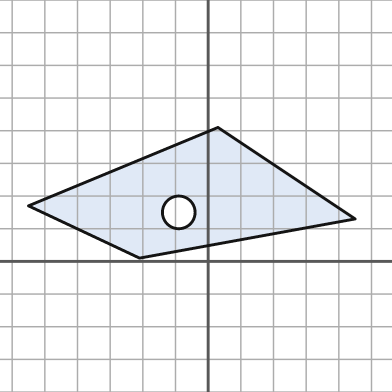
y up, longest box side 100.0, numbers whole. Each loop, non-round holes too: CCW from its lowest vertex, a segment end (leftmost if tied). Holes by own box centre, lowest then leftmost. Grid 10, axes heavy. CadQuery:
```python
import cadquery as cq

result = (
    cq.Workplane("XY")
    .moveTo(-21.0, 1.0)
    .lineTo(45.0, 13.0)
    .lineTo(3.0, 41.0)
    .lineTo(-55.0, 17.0)
    .close()
    .moveTo(-9.0, 15.0)
    .circle(5.0)
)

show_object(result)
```